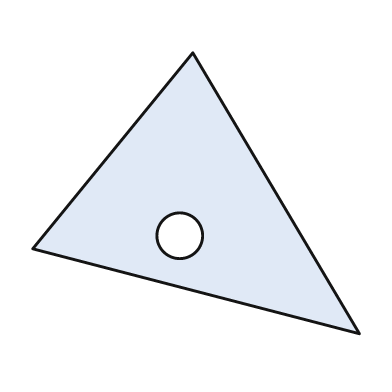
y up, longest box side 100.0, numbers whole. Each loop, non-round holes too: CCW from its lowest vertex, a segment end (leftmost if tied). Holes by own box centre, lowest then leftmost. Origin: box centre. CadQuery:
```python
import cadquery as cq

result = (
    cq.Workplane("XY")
    .moveTo(50.0, -43.0)
    .lineTo(-1.0, 43.0)
    .lineTo(-50.0, -17.0)
    .close()
    .moveTo(-5.0, -13.0)
    .circle(7.0)
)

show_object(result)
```